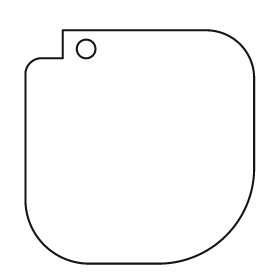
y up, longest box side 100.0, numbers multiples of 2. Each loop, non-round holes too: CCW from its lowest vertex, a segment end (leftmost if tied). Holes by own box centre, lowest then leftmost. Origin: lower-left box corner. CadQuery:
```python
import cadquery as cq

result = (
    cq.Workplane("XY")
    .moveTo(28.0, 0.0)
    .lineTo(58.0, 0.0)
    .threePointArc((86.0, 12.0), (98.0, 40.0))
    .lineTo(98.0, 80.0)
    .threePointArc((92.0, 94.0), (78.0, 100.0))
    .lineTo(16.0, 100.0)
    .lineTo(16.0, 88.0)
    .lineTo(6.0, 88.0)
    .threePointArc((2.0, 86.0), (0.0, 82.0))
    .lineTo(0.0, 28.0)
    .threePointArc((8.0, 8.0), (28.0, 0.0))
    .close()
    .moveTo(26.0, 92.0)
    .circle(4.0)
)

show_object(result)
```